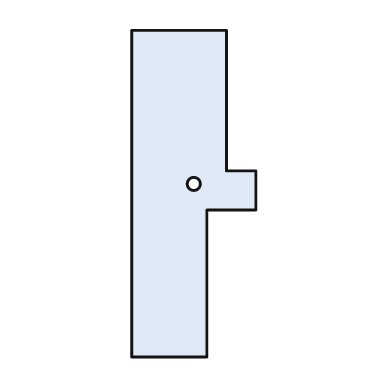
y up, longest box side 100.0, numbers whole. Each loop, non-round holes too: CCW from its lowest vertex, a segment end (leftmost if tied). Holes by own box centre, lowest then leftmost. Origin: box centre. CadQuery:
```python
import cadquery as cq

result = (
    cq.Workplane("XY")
    .moveTo(-19.0, -50.0)
    .lineTo(4.0, -50.0)
    .lineTo(4.0, -5.0)
    .lineTo(19.0, -5.0)
    .lineTo(19.0, 7.0)
    .lineTo(10.0, 7.0)
    .lineTo(10.0, 50.0)
    .lineTo(-19.0, 50.0)
    .close()
    .moveTo(0.0, 3.0)
    .circle(2.0)
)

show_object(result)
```